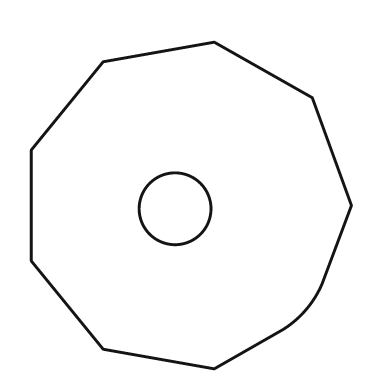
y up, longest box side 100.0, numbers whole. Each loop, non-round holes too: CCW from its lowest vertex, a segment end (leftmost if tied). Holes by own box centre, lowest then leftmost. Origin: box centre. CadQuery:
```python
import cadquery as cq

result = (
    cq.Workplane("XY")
    .moveTo(7.0, -50.0)
    .lineTo(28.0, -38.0)
    .threePointArc((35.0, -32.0), (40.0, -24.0))
    .lineTo(49.0, 0.0)
    .lineTo(37.0, 33.0)
    .lineTo(7.0, 50.0)
    .lineTo(-27.0, 44.0)
    .lineTo(-49.0, 17.0)
    .lineTo(-49.0, -17.0)
    .lineTo(-27.0, -44.0)
    .close()
    .moveTo(-5.0, -1.0)
    .circle(11.0)
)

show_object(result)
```